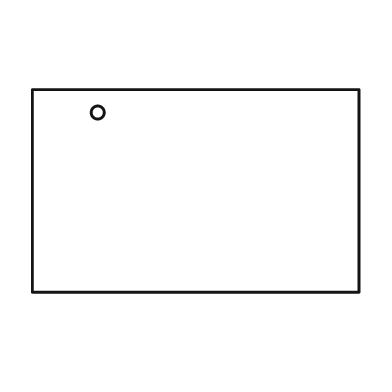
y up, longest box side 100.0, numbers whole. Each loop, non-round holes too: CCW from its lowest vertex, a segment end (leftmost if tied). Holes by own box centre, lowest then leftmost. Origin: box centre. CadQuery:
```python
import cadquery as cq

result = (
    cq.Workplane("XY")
    .moveTo(-50.0, -31.0)
    .lineTo(50.0, -31.0)
    .lineTo(50.0, 31.0)
    .lineTo(-50.0, 31.0)
    .close()
    .moveTo(-30.0, 24.0)
    .circle(2.0)
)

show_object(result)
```